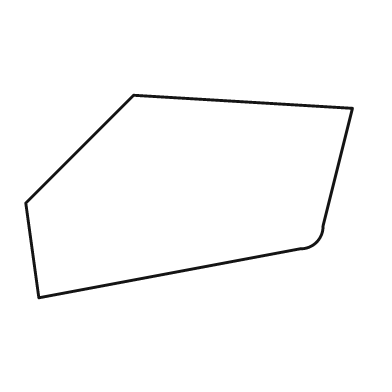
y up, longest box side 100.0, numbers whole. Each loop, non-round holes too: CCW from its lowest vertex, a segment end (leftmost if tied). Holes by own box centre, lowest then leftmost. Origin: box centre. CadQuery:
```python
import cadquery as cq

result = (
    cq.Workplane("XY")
    .moveTo(-46.0, -31.0)
    .lineTo(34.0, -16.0)
    .threePointArc((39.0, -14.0), (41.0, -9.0))
    .lineTo(50.0, 27.0)
    .lineTo(-17.0, 31.0)
    .lineTo(-50.0, -2.0)
    .close()
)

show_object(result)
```